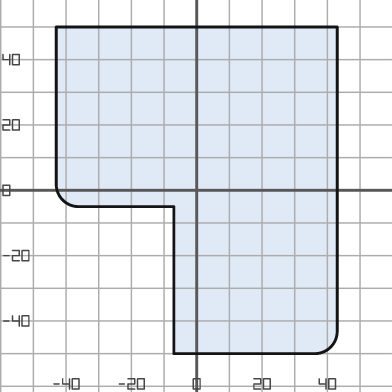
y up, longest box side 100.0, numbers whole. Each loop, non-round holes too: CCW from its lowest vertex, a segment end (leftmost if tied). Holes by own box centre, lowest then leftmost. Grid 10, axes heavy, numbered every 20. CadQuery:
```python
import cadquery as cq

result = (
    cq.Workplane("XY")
    .moveTo(-7.0, -50.0)
    .lineTo(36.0, -50.0)
    .threePointArc((41.0, -48.0), (43.0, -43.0))
    .lineTo(43.0, 50.0)
    .lineTo(-43.0, 50.0)
    .lineTo(-43.0, 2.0)
    .threePointArc((-41.0, -3.0), (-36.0, -5.0))
    .lineTo(-7.0, -5.0)
    .close()
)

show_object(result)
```